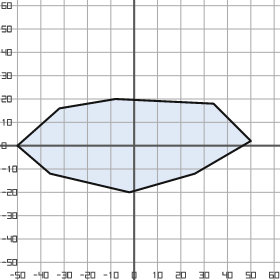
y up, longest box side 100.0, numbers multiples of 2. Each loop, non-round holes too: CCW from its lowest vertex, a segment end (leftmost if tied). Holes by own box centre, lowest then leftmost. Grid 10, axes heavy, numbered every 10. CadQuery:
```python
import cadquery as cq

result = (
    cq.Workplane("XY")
    .moveTo(-2.0, -20.0)
    .lineTo(26.0, -12.0)
    .lineTo(50.0, 2.0)
    .lineTo(34.0, 18.0)
    .lineTo(-8.0, 20.0)
    .lineTo(-32.0, 16.0)
    .lineTo(-50.0, 0.0)
    .lineTo(-36.0, -12.0)
    .close()
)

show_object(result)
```